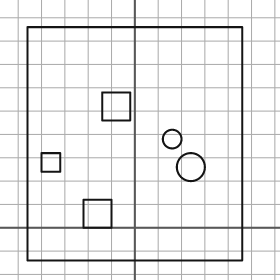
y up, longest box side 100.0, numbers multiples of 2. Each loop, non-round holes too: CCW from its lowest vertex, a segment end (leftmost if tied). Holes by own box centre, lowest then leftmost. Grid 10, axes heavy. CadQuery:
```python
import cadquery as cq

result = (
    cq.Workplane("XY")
    .moveTo(-46.0, -14.0)
    .lineTo(46.0, -14.0)
    .lineTo(46.0, 86.0)
    .lineTo(-46.0, 86.0)
    .close()
    .moveTo(-22.0, 0.0)
    .lineTo(-10.0, 0.0)
    .lineTo(-10.0, 12.0)
    .lineTo(-22.0, 12.0)
    .close()
    .moveTo(24.0, 26.0)
    .circle(6.0)
    .moveTo(-40.0, 24.0)
    .lineTo(-32.0, 24.0)
    .lineTo(-32.0, 32.0)
    .lineTo(-40.0, 32.0)
    .close()
    .moveTo(16.0, 38.0)
    .circle(4.0)
    .moveTo(-14.0, 46.0)
    .lineTo(-2.0, 46.0)
    .lineTo(-2.0, 58.0)
    .lineTo(-14.0, 58.0)
    .close()
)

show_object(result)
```